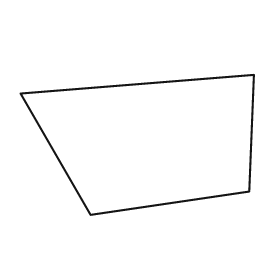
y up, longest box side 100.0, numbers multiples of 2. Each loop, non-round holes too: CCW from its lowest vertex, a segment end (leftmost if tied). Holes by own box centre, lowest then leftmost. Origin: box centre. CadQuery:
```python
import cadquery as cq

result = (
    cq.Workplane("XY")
    .moveTo(-20.0, -30.0)
    .lineTo(48.0, -20.0)
    .lineTo(50.0, 30.0)
    .lineTo(-50.0, 22.0)
    .close()
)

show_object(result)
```